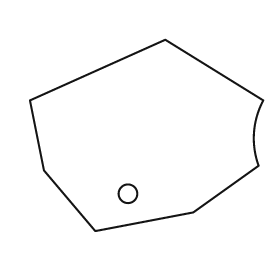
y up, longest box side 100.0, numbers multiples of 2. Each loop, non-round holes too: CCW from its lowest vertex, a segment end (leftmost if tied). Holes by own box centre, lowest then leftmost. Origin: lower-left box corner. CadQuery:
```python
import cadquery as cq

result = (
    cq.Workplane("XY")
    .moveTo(28.0, 0.0)
    .lineTo(70.0, 8.0)
    .lineTo(98.0, 28.0)
    .threePointArc((96.0, 42.0), (100.0, 56.0))
    .lineTo(58.0, 82.0)
    .lineTo(0.0, 56.0)
    .lineTo(6.0, 26.0)
    .close()
    .moveTo(42.0, 16.0)
    .circle(4.0)
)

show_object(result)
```